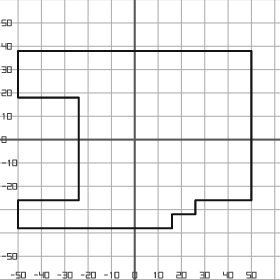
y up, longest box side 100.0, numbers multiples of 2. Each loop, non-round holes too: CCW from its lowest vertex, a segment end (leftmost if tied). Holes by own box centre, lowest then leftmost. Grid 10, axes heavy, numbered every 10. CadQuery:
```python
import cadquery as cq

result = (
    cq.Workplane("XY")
    .moveTo(-50.0, -38.0)
    .lineTo(16.0, -38.0)
    .lineTo(16.0, -32.0)
    .lineTo(26.0, -32.0)
    .lineTo(26.0, -26.0)
    .lineTo(50.0, -26.0)
    .lineTo(50.0, 38.0)
    .lineTo(-50.0, 38.0)
    .lineTo(-50.0, 18.0)
    .lineTo(-24.0, 18.0)
    .lineTo(-24.0, -26.0)
    .lineTo(-50.0, -26.0)
    .close()
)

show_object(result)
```